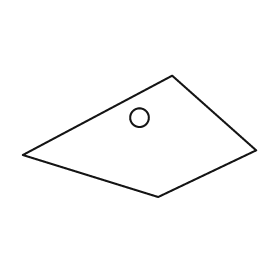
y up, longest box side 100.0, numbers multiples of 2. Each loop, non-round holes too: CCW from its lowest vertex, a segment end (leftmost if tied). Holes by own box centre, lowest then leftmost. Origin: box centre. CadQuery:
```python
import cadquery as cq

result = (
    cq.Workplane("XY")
    .moveTo(8.0, -26.0)
    .lineTo(50.0, -6.0)
    .lineTo(14.0, 26.0)
    .lineTo(-50.0, -8.0)
    .close()
    .moveTo(0.0, 8.0)
    .circle(4.0)
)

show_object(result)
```